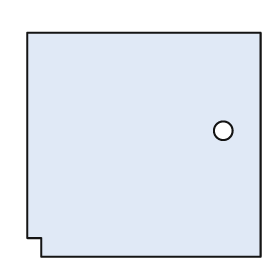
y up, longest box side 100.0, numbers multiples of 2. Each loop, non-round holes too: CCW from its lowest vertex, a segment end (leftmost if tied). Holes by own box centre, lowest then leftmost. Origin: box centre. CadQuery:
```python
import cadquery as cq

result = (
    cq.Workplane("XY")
    .moveTo(-44.0, -48.0)
    .lineTo(50.0, -48.0)
    .lineTo(50.0, 48.0)
    .lineTo(-50.0, 48.0)
    .lineTo(-50.0, -40.0)
    .lineTo(-44.0, -40.0)
    .close()
    .moveTo(34.0, 6.0)
    .circle(4.0)
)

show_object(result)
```